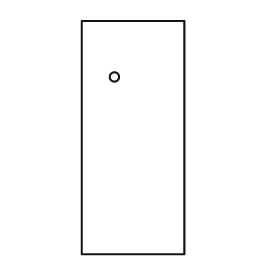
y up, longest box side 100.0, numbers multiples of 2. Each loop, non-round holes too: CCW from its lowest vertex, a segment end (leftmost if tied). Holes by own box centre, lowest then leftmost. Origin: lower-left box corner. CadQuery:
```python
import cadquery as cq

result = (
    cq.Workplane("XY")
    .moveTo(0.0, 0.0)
    .lineTo(44.0, 0.0)
    .lineTo(44.0, 100.0)
    .lineTo(0.0, 100.0)
    .close()
    .moveTo(14.0, 76.0)
    .circle(2.0)
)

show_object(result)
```